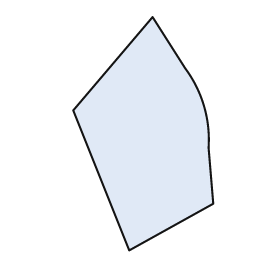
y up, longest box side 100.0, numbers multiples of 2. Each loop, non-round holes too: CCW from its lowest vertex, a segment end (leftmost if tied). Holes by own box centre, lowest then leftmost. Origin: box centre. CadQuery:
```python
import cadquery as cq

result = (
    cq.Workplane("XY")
    .moveTo(-6.0, -50.0)
    .lineTo(30.0, -30.0)
    .lineTo(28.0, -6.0)
    .threePointArc((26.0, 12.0), (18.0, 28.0))
    .lineTo(4.0, 50.0)
    .lineTo(-30.0, 10.0)
    .close()
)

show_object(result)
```